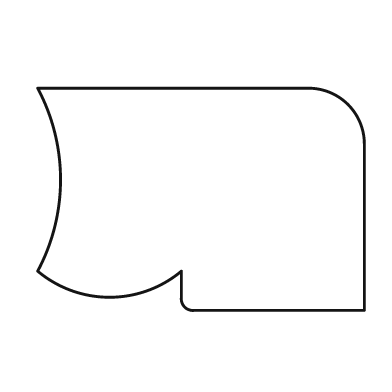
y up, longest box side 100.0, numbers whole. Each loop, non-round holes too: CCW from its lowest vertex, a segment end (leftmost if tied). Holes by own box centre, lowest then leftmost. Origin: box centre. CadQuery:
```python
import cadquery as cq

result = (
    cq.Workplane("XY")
    .moveTo(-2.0, -34.0)
    .lineTo(50.0, -34.0)
    .lineTo(50.0, 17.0)
    .threePointArc((45.0, 29.0), (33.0, 34.0))
    .lineTo(-50.0, 34.0)
    .threePointArc((-43.0, 6.0), (-50.0, -22.0))
    .threePointArc((-28.0, -30.0), (-6.0, -22.0))
    .lineTo(-6.0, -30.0)
    .threePointArc((-5.0, -33.0), (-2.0, -34.0))
    .close()
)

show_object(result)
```